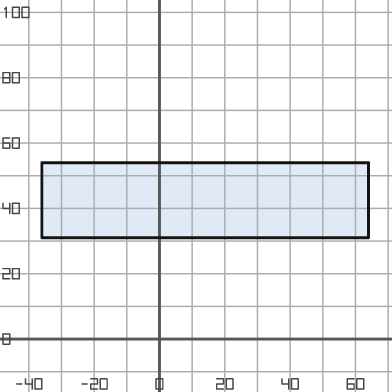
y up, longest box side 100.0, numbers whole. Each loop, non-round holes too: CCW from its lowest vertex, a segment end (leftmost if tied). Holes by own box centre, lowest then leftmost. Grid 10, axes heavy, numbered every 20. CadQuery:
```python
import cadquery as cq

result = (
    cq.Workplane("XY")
    .moveTo(-36.0, 31.0)
    .lineTo(64.0, 31.0)
    .lineTo(64.0, 54.0)
    .lineTo(-36.0, 54.0)
    .close()
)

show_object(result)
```